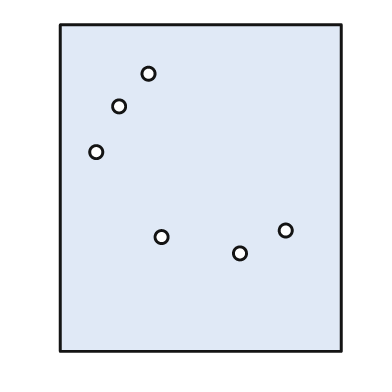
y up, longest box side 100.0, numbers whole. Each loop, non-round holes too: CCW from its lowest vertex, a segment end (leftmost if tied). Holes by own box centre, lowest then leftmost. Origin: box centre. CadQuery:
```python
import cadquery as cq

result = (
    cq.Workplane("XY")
    .moveTo(-43.0, -50.0)
    .lineTo(43.0, -50.0)
    .lineTo(43.0, 50.0)
    .lineTo(-43.0, 50.0)
    .close()
    .moveTo(12.0, -20.0)
    .circle(2.0)
    .moveTo(-12.0, -15.0)
    .circle(2.0)
    .moveTo(26.0, -13.0)
    .circle(2.0)
    .moveTo(-32.0, 11.0)
    .circle(2.0)
    .moveTo(-25.0, 25.0)
    .circle(2.0)
    .moveTo(-16.0, 35.0)
    .circle(2.0)
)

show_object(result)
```